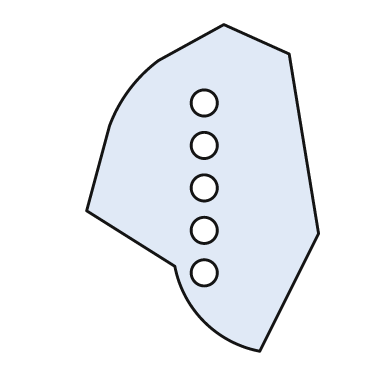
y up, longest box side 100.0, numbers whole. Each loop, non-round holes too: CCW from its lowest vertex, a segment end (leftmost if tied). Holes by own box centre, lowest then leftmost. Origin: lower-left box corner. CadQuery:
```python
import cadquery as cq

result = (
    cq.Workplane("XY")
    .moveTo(53.0, 0.0)
    .lineTo(71.0, 36.0)
    .lineTo(62.0, 91.0)
    .lineTo(42.0, 100.0)
    .lineTo(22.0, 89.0)
    .threePointArc((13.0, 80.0), (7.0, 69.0))
    .lineTo(0.0, 43.0)
    .lineTo(27.0, 26.0)
    .threePointArc((36.0, 9.0), (53.0, 0.0))
    .close()
    .moveTo(36.0, 24.0)
    .circle(4.0)
    .moveTo(36.0, 37.0)
    .circle(4.0)
    .moveTo(36.0, 50.0)
    .circle(4.0)
    .moveTo(36.0, 63.0)
    .circle(4.0)
    .moveTo(36.0, 76.0)
    .circle(4.0)
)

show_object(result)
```